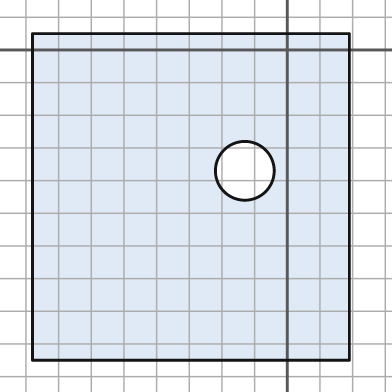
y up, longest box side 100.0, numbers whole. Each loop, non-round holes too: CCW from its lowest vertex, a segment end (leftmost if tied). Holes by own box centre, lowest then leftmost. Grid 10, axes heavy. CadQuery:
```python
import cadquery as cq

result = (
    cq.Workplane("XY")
    .moveTo(-78.0, -95.0)
    .lineTo(19.0, -95.0)
    .lineTo(19.0, 5.0)
    .lineTo(-78.0, 5.0)
    .close()
    .moveTo(-13.0, -37.0)
    .circle(9.0)
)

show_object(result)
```